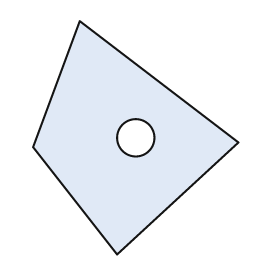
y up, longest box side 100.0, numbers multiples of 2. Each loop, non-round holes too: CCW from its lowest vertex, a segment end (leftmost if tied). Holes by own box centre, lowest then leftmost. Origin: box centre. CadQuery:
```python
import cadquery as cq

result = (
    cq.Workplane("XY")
    .moveTo(-8.0, -50.0)
    .lineTo(44.0, -2.0)
    .lineTo(-24.0, 50.0)
    .lineTo(-44.0, -4.0)
    .close()
    .moveTo(0.0, 0.0)
    .circle(8.0)
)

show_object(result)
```